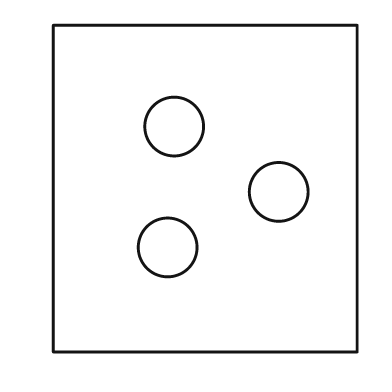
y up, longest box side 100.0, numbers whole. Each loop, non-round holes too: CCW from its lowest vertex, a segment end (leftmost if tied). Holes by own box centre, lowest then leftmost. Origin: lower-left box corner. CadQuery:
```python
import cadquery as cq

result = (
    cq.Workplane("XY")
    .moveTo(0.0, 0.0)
    .lineTo(93.0, 0.0)
    .lineTo(93.0, 100.0)
    .lineTo(0.0, 100.0)
    .close()
    .moveTo(35.0, 32.0)
    .circle(9.0)
    .moveTo(69.0, 49.0)
    .circle(9.0)
    .moveTo(37.0, 69.0)
    .circle(9.0)
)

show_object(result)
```